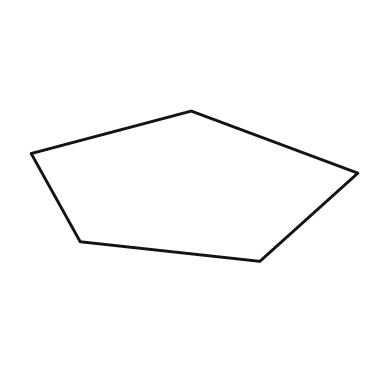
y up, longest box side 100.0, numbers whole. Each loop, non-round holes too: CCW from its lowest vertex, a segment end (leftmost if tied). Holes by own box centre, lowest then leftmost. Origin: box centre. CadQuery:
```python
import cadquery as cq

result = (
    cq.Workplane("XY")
    .moveTo(20.0, -23.0)
    .lineTo(50.0, 4.0)
    .lineTo(-1.0, 23.0)
    .lineTo(-50.0, 10.0)
    .lineTo(-35.0, -17.0)
    .close()
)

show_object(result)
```